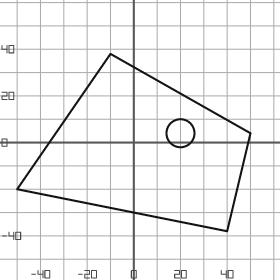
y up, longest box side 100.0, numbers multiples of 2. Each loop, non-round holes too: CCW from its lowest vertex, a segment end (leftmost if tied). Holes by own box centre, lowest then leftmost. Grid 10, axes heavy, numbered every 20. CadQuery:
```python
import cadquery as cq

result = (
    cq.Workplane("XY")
    .moveTo(40.0, -38.0)
    .lineTo(50.0, 4.0)
    .lineTo(-10.0, 38.0)
    .lineTo(-50.0, -20.0)
    .close()
    .moveTo(20.0, 4.0)
    .circle(6.0)
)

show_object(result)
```